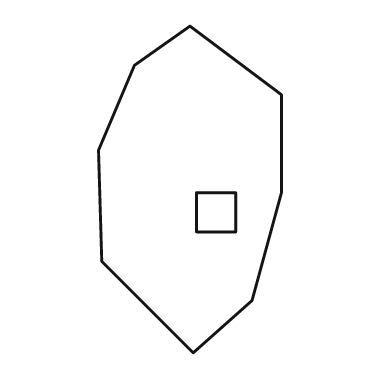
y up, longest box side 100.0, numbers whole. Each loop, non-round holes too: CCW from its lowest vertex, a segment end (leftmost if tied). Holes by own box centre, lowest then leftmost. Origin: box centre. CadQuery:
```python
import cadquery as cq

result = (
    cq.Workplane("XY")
    .moveTo(1.0, -50.0)
    .lineTo(19.0, -34.0)
    .lineTo(28.0, -1.0)
    .lineTo(28.0, 29.0)
    .lineTo(0.0, 50.0)
    .lineTo(-17.0, 38.0)
    .lineTo(-28.0, 12.0)
    .lineTo(-27.0, -22.0)
    .close()
    .moveTo(2.0, -13.0)
    .lineTo(14.0, -13.0)
    .lineTo(14.0, -1.0)
    .lineTo(2.0, -1.0)
    .close()
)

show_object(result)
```